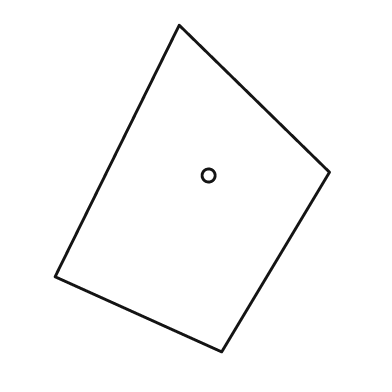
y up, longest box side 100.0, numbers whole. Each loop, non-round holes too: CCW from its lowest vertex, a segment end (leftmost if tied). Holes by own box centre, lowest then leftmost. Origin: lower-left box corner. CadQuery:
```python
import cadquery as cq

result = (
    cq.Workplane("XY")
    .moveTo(51.0, 0.0)
    .lineTo(84.0, 55.0)
    .lineTo(38.0, 100.0)
    .lineTo(0.0, 23.0)
    .close()
    .moveTo(47.0, 54.0)
    .circle(2.0)
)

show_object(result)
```